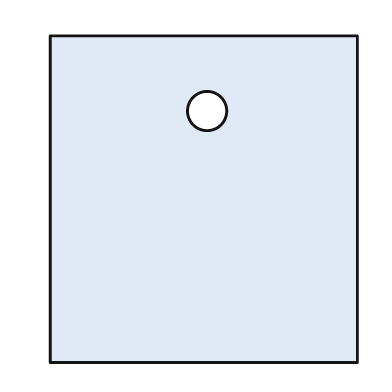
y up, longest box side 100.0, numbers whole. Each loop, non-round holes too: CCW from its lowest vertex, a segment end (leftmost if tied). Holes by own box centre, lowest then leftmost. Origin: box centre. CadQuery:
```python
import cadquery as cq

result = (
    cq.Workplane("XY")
    .moveTo(-47.0, -50.0)
    .lineTo(47.0, -50.0)
    .lineTo(47.0, 50.0)
    .lineTo(-47.0, 50.0)
    .close()
    .moveTo(1.0, 27.0)
    .circle(6.0)
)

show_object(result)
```